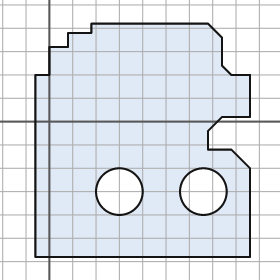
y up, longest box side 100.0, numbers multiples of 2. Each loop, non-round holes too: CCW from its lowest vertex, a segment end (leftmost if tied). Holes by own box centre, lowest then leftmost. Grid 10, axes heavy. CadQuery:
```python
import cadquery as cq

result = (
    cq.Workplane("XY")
    .moveTo(-6.0, -58.0)
    .lineTo(86.0, -58.0)
    .lineTo(86.0, -20.0)
    .lineTo(78.0, -12.0)
    .lineTo(68.0, -12.0)
    .lineTo(68.0, -4.0)
    .lineTo(74.0, 2.0)
    .lineTo(86.0, 2.0)
    .lineTo(86.0, 20.0)
    .lineTo(78.0, 20.0)
    .lineTo(74.0, 24.0)
    .lineTo(74.0, 36.0)
    .lineTo(68.0, 42.0)
    .lineTo(18.0, 42.0)
    .lineTo(18.0, 38.0)
    .lineTo(8.0, 38.0)
    .lineTo(8.0, 32.0)
    .lineTo(0.0, 32.0)
    .lineTo(0.0, 20.0)
    .lineTo(-6.0, 20.0)
    .close()
    .moveTo(30.0, -30.0)
    .circle(10.0)
    .moveTo(66.0, -30.0)
    .circle(10.0)
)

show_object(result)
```